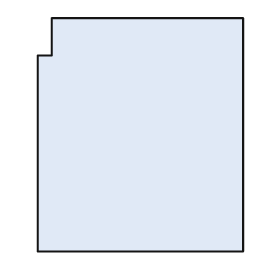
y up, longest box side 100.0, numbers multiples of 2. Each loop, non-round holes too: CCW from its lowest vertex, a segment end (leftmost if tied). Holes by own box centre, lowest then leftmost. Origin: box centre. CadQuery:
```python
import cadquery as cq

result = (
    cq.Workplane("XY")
    .moveTo(-44.0, -50.0)
    .lineTo(44.0, -50.0)
    .lineTo(44.0, 50.0)
    .lineTo(-38.0, 50.0)
    .lineTo(-38.0, 34.0)
    .lineTo(-44.0, 34.0)
    .close()
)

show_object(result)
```